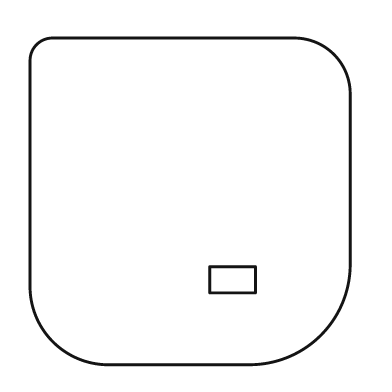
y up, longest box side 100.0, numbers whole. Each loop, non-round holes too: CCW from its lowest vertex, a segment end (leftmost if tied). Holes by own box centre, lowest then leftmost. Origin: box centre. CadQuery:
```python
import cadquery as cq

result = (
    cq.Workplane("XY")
    .moveTo(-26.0, -50.0)
    .lineTo(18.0, -50.0)
    .threePointArc((40.0, -41.0), (49.0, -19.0))
    .lineTo(49.0, 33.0)
    .threePointArc((44.0, 45.0), (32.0, 50.0))
    .lineTo(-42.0, 50.0)
    .threePointArc((-47.0, 48.0), (-49.0, 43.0))
    .lineTo(-49.0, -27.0)
    .threePointArc((-42.0, -43.0), (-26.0, -50.0))
    .close()
    .moveTo(6.0, -28.0)
    .lineTo(20.0, -28.0)
    .lineTo(20.0, -20.0)
    .lineTo(6.0, -20.0)
    .close()
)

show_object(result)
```